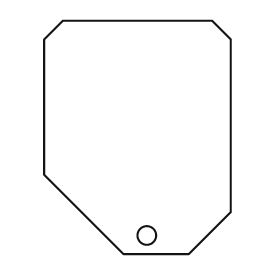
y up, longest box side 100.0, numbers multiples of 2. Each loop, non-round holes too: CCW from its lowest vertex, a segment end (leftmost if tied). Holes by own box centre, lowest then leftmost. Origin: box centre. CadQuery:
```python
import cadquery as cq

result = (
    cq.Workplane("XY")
    .moveTo(-6.0, -50.0)
    .lineTo(22.0, -50.0)
    .lineTo(40.0, -32.0)
    .lineTo(40.0, 42.0)
    .lineTo(32.0, 50.0)
    .lineTo(-32.0, 50.0)
    .lineTo(-40.0, 42.0)
    .lineTo(-40.0, -16.0)
    .close()
    .moveTo(4.0, -42.0)
    .circle(4.0)
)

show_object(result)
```